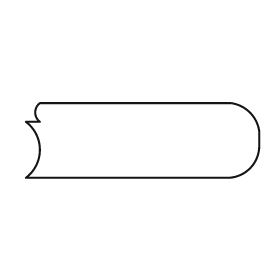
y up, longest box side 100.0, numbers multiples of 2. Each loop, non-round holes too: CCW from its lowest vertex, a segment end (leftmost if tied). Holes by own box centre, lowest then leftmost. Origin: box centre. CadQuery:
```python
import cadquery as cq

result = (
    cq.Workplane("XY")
    .moveTo(-50.0, -16.0)
    .lineTo(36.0, -16.0)
    .threePointArc((46.0, -12.0), (50.0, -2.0))
    .lineTo(50.0, 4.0)
    .threePointArc((46.0, 12.0), (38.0, 16.0))
    .lineTo(-44.0, 16.0)
    .threePointArc((-46.0, 12.0), (-44.0, 8.0))
    .lineTo(-50.0, 8.0)
    .threePointArc((-44.0, -4.0), (-50.0, -16.0))
    .close()
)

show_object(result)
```